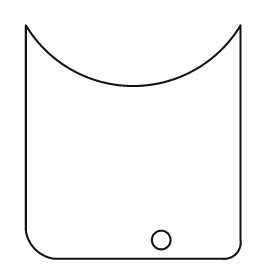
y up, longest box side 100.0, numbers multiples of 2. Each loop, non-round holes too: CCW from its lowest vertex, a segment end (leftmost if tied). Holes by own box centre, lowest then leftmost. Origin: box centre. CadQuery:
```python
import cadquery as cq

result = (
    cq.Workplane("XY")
    .moveTo(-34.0, -50.0)
    .lineTo(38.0, -50.0)
    .threePointArc((44.0, -48.0), (46.0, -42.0))
    .lineTo(46.0, 50.0)
    .threePointArc((0.0, 24.0), (-46.0, 50.0))
    .lineTo(-46.0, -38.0)
    .threePointArc((-42.0, -46.0), (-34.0, -50.0))
    .close()
    .moveTo(12.0, -42.0)
    .circle(4.0)
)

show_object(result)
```